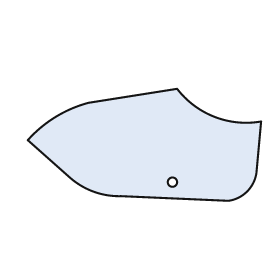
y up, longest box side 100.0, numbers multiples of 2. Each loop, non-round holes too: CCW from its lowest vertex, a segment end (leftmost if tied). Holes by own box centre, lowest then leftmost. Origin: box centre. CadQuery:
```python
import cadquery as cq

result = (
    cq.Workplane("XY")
    .moveTo(36.0, -24.0)
    .threePointArc((44.0, -20.0), (48.0, -12.0))
    .lineTo(50.0, 10.0)
    .threePointArc((30.0, 12.0), (14.0, 24.0))
    .lineTo(-24.0, 18.0)
    .threePointArc((-38.0, 12.0), (-50.0, 2.0))
    .lineTo(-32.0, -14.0)
    .threePointArc((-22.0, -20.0), (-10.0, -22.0))
    .close()
    .moveTo(12.0, -16.0)
    .circle(2.0)
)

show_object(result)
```